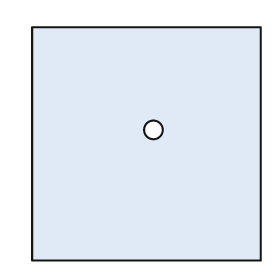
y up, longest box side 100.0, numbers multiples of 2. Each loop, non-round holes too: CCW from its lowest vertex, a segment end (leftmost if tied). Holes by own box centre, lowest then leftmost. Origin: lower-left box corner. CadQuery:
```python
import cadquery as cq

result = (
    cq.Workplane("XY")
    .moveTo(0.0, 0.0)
    .lineTo(98.0, 0.0)
    .lineTo(98.0, 100.0)
    .lineTo(0.0, 100.0)
    .close()
    .moveTo(52.0, 56.0)
    .circle(4.0)
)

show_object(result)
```